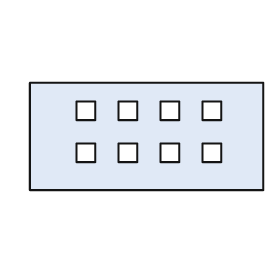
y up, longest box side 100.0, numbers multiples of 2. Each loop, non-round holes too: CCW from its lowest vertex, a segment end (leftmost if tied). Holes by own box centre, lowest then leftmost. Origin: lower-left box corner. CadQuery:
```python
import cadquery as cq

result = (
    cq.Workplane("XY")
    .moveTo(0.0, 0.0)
    .lineTo(100.0, 0.0)
    .lineTo(100.0, 46.0)
    .lineTo(0.0, 46.0)
    .close()
    .moveTo(20.0, 12.0)
    .lineTo(28.0, 12.0)
    .lineTo(28.0, 20.0)
    .lineTo(20.0, 20.0)
    .close()
    .moveTo(38.0, 12.0)
    .lineTo(46.0, 12.0)
    .lineTo(46.0, 20.0)
    .lineTo(38.0, 20.0)
    .close()
    .moveTo(56.0, 12.0)
    .lineTo(64.0, 12.0)
    .lineTo(64.0, 20.0)
    .lineTo(56.0, 20.0)
    .close()
    .moveTo(74.0, 12.0)
    .lineTo(82.0, 12.0)
    .lineTo(82.0, 20.0)
    .lineTo(74.0, 20.0)
    .close()
    .moveTo(20.0, 30.0)
    .lineTo(28.0, 30.0)
    .lineTo(28.0, 38.0)
    .lineTo(20.0, 38.0)
    .close()
    .moveTo(38.0, 30.0)
    .lineTo(46.0, 30.0)
    .lineTo(46.0, 38.0)
    .lineTo(38.0, 38.0)
    .close()
    .moveTo(56.0, 30.0)
    .lineTo(64.0, 30.0)
    .lineTo(64.0, 38.0)
    .lineTo(56.0, 38.0)
    .close()
    .moveTo(74.0, 30.0)
    .lineTo(82.0, 30.0)
    .lineTo(82.0, 38.0)
    .lineTo(74.0, 38.0)
    .close()
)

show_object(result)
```